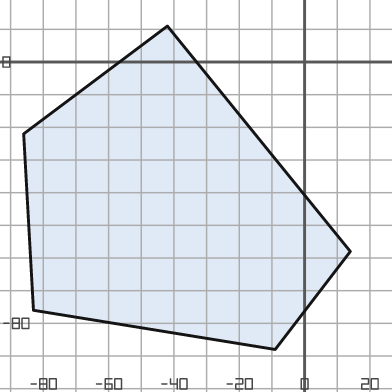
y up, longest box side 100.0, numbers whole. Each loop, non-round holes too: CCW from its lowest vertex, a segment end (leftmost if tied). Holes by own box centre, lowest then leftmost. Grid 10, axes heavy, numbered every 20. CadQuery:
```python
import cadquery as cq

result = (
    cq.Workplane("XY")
    .moveTo(-9.0, -88.0)
    .lineTo(14.0, -58.0)
    .lineTo(-42.0, 11.0)
    .lineTo(-86.0, -22.0)
    .lineTo(-83.0, -76.0)
    .close()
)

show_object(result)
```